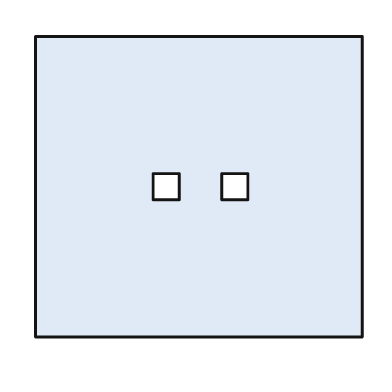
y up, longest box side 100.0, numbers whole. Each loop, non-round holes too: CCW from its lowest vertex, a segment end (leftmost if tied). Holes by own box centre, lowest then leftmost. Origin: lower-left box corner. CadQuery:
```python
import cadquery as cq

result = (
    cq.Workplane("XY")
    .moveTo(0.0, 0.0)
    .lineTo(100.0, 0.0)
    .lineTo(100.0, 92.0)
    .lineTo(0.0, 92.0)
    .close()
    .moveTo(36.0, 42.0)
    .lineTo(44.0, 42.0)
    .lineTo(44.0, 50.0)
    .lineTo(36.0, 50.0)
    .close()
    .moveTo(57.0, 42.0)
    .lineTo(65.0, 42.0)
    .lineTo(65.0, 50.0)
    .lineTo(57.0, 50.0)
    .close()
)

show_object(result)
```